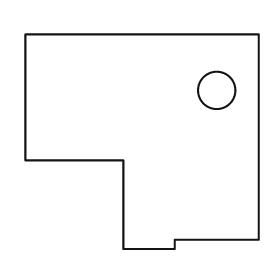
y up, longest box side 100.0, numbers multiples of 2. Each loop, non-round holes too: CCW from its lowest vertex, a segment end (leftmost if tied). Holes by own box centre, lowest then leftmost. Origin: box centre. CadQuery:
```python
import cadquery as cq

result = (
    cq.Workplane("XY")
    .moveTo(-8.0, -46.0)
    .lineTo(14.0, -46.0)
    .lineTo(14.0, -42.0)
    .lineTo(50.0, -42.0)
    .lineTo(50.0, 46.0)
    .lineTo(-50.0, 46.0)
    .lineTo(-50.0, -8.0)
    .lineTo(-8.0, -8.0)
    .close()
    .moveTo(32.0, 22.0)
    .circle(8.0)
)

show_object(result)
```